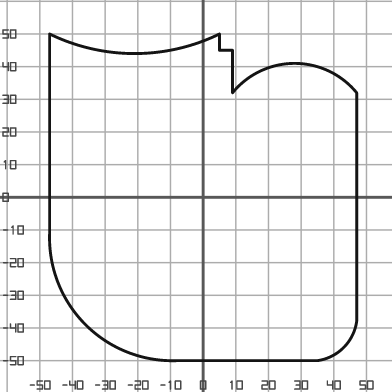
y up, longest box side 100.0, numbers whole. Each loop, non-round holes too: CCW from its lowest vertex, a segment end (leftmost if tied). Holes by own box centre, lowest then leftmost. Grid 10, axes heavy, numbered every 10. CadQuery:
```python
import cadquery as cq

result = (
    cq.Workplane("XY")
    .moveTo(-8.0, -50.0)
    .lineTo(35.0, -50.0)
    .threePointArc((43.0, -46.0), (47.0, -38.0))
    .lineTo(47.0, 32.0)
    .threePointArc((28.0, 41.0), (9.0, 32.0))
    .lineTo(9.0, 45.0)
    .lineTo(5.0, 45.0)
    .lineTo(5.0, 50.0)
    .threePointArc((-21.0, 44.0), (-47.0, 50.0))
    .lineTo(-47.0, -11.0)
    .threePointArc((-36.0, -39.0), (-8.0, -50.0))
    .close()
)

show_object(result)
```